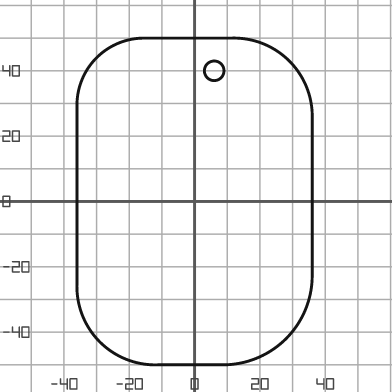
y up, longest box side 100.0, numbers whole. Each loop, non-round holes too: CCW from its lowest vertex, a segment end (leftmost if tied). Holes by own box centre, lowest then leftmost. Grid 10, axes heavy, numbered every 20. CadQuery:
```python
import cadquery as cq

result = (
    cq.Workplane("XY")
    .moveTo(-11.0, -50.0)
    .lineTo(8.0, -50.0)
    .threePointArc((28.0, -42.0), (36.0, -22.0))
    .lineTo(36.0, 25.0)
    .threePointArc((29.0, 43.0), (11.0, 50.0))
    .lineTo(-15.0, 50.0)
    .threePointArc((-30.0, 44.0), (-36.0, 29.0))
    .lineTo(-36.0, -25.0)
    .threePointArc((-29.0, -43.0), (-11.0, -50.0))
    .close()
    .moveTo(6.0, 40.0)
    .circle(3.0)
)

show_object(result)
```